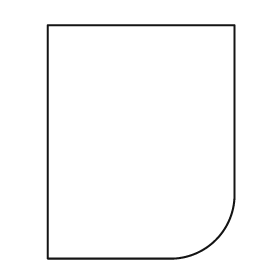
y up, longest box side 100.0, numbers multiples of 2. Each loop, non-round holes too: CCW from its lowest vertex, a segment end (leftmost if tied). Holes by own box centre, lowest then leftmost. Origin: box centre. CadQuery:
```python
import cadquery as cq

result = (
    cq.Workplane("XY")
    .moveTo(-40.0, -50.0)
    .lineTo(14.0, -50.0)
    .threePointArc((32.0, -42.0), (40.0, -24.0))
    .lineTo(40.0, 50.0)
    .lineTo(-40.0, 50.0)
    .close()
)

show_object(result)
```